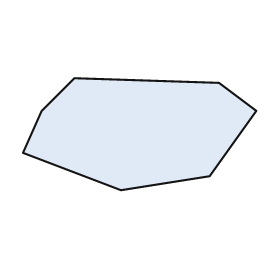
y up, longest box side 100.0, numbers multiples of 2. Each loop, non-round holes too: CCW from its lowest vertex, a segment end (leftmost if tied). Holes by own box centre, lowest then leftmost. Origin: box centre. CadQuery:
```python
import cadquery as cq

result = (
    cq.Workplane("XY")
    .moveTo(-8.0, -24.0)
    .lineTo(30.0, -18.0)
    .lineTo(50.0, 10.0)
    .lineTo(34.0, 22.0)
    .lineTo(-28.0, 24.0)
    .lineTo(-42.0, 10.0)
    .lineTo(-50.0, -8.0)
    .close()
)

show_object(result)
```